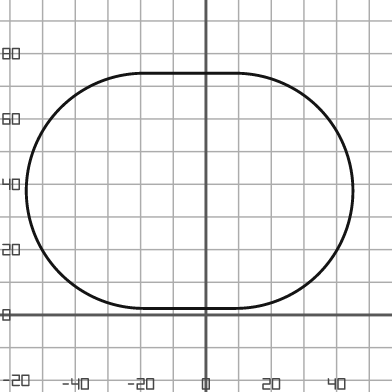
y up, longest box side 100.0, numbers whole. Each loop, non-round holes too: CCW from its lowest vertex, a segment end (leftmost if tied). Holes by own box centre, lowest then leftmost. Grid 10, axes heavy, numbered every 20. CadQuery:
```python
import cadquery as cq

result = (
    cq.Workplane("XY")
    .moveTo(-19.0, 2.0)
    .lineTo(9.0, 2.0)
    .threePointArc((45.0, 38.0), (9.0, 74.0))
    .lineTo(-19.0, 74.0)
    .threePointArc((-55.0, 38.0), (-19.0, 2.0))
    .close()
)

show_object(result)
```